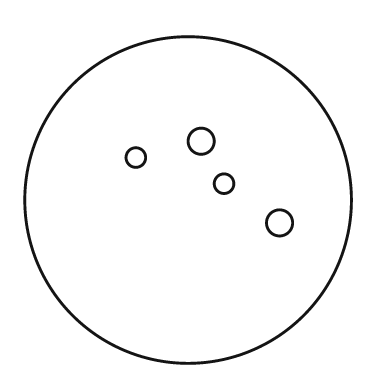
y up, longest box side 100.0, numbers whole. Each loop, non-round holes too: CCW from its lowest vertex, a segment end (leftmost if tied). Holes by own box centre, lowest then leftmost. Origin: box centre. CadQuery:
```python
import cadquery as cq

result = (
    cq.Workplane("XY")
    .moveTo(0.0, 0.0)
    .circle(50.0)
    .moveTo(28.0, -7.0)
    .circle(4.0)
    .moveTo(11.0, 5.0)
    .circle(3.0)
    .moveTo(-16.0, 13.0)
    .circle(3.0)
    .moveTo(4.0, 18.0)
    .circle(4.0)
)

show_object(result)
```